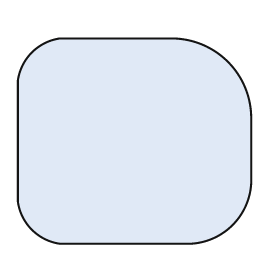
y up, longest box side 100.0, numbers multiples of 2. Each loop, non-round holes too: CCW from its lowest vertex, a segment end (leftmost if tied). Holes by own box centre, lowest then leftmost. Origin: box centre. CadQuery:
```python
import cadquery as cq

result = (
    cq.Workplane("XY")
    .moveTo(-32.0, -44.0)
    .lineTo(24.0, -44.0)
    .threePointArc((42.0, -36.0), (50.0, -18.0))
    .lineTo(50.0, 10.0)
    .threePointArc((40.0, 34.0), (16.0, 44.0))
    .lineTo(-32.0, 44.0)
    .threePointArc((-44.0, 38.0), (-50.0, 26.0))
    .lineTo(-50.0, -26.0)
    .threePointArc((-44.0, -38.0), (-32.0, -44.0))
    .close()
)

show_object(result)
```